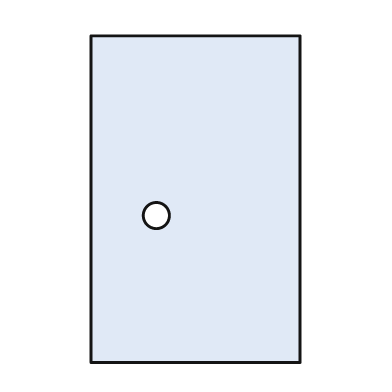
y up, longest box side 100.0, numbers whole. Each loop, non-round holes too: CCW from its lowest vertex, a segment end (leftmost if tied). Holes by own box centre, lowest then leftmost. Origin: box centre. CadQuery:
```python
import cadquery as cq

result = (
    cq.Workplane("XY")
    .moveTo(-32.0, -50.0)
    .lineTo(32.0, -50.0)
    .lineTo(32.0, 50.0)
    .lineTo(-32.0, 50.0)
    .close()
    .moveTo(-12.0, -5.0)
    .circle(4.0)
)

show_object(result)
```